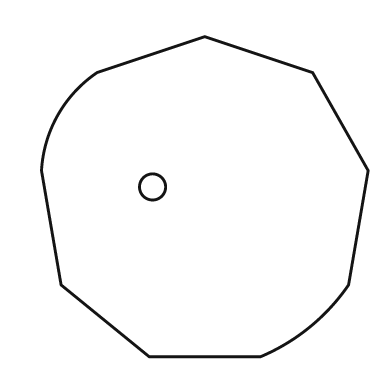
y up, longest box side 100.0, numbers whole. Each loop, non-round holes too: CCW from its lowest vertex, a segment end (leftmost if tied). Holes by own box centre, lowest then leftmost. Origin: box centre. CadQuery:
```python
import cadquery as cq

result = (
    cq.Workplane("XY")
    .moveTo(-17.0, -49.0)
    .lineTo(17.0, -49.0)
    .threePointArc((32.0, -40.0), (44.0, -27.0))
    .lineTo(50.0, 8.0)
    .lineTo(33.0, 38.0)
    .lineTo(0.0, 49.0)
    .lineTo(-33.0, 38.0)
    .threePointArc((-45.0, 25.0), (-50.0, 8.0))
    .lineTo(-44.0, -27.0)
    .close()
    .moveTo(-16.0, 3.0)
    .circle(4.0)
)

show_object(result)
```